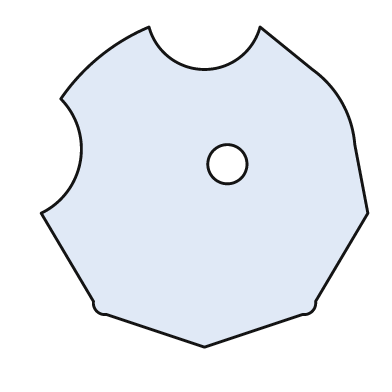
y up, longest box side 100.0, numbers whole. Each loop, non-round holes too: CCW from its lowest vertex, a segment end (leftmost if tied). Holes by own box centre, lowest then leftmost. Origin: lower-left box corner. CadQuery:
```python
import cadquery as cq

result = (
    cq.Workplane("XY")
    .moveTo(50.0, 0.0)
    .lineTo(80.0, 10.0)
    .threePointArc((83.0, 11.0), (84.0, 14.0))
    .lineTo(100.0, 41.0)
    .lineTo(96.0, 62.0)
    .threePointArc((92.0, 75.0), (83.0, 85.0))
    .lineTo(67.0, 98.0)
    .threePointArc((50.0, 85.0), (33.0, 98.0))
    .threePointArc((18.0, 89.0), (6.0, 76.0))
    .threePointArc((12.0, 57.0), (0.0, 41.0))
    .lineTo(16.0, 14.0)
    .threePointArc((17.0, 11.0), (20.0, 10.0))
    .close()
    .moveTo(57.0, 56.0)
    .circle(6.0)
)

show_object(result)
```